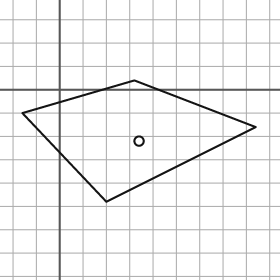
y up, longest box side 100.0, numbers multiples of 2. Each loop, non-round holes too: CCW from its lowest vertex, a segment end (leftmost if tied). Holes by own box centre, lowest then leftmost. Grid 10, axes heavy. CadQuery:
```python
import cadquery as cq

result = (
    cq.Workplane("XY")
    .moveTo(20.0, -48.0)
    .lineTo(84.0, -16.0)
    .lineTo(32.0, 4.0)
    .lineTo(-16.0, -10.0)
    .close()
    .moveTo(34.0, -22.0)
    .circle(2.0)
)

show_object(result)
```